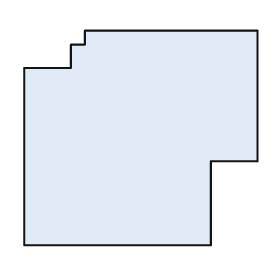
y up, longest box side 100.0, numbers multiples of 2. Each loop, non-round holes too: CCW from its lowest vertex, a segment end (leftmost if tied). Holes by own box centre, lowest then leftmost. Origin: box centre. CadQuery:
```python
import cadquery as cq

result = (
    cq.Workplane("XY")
    .moveTo(-50.0, -46.0)
    .lineTo(30.0, -46.0)
    .lineTo(30.0, -10.0)
    .lineTo(50.0, -10.0)
    .lineTo(50.0, 46.0)
    .lineTo(-24.0, 46.0)
    .lineTo(-24.0, 40.0)
    .lineTo(-30.0, 40.0)
    .lineTo(-30.0, 30.0)
    .lineTo(-50.0, 30.0)
    .close()
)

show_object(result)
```